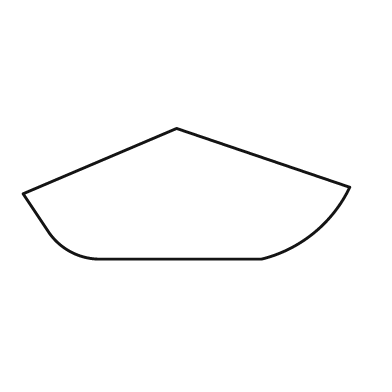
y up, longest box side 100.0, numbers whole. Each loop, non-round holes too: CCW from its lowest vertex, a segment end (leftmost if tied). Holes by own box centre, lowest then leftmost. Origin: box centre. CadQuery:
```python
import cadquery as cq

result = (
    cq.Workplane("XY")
    .moveTo(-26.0, -20.0)
    .lineTo(23.0, -20.0)
    .threePointArc((39.0, -12.0), (50.0, 2.0))
    .lineTo(-3.0, 20.0)
    .lineTo(-50.0, 0.0)
    .lineTo(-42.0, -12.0)
    .threePointArc((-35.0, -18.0), (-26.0, -20.0))
    .close()
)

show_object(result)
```